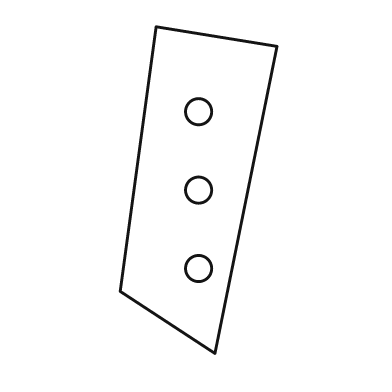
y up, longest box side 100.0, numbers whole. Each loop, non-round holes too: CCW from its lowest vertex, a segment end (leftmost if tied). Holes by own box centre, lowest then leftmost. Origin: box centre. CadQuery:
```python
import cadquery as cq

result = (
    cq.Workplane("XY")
    .moveTo(5.0, -50.0)
    .lineTo(24.0, 44.0)
    .lineTo(-13.0, 50.0)
    .lineTo(-24.0, -31.0)
    .close()
    .moveTo(0.0, -24.0)
    .circle(4.0)
    .moveTo(0.0, 0.0)
    .circle(4.0)
    .moveTo(0.0, 24.0)
    .circle(4.0)
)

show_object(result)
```